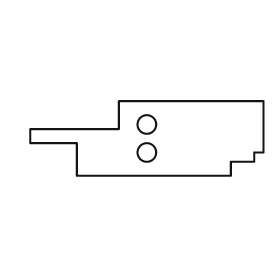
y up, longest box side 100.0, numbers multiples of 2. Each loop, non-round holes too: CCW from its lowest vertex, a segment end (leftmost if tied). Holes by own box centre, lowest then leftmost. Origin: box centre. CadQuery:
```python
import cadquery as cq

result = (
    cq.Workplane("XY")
    .moveTo(-30.0, -16.0)
    .lineTo(36.0, -16.0)
    .lineTo(36.0, -10.0)
    .lineTo(46.0, -10.0)
    .lineTo(46.0, -6.0)
    .lineTo(50.0, -6.0)
    .lineTo(50.0, 16.0)
    .lineTo(-12.0, 16.0)
    .lineTo(-12.0, 4.0)
    .lineTo(-50.0, 4.0)
    .lineTo(-50.0, -2.0)
    .lineTo(-30.0, -2.0)
    .close()
    .moveTo(0.0, -6.0)
    .circle(4.0)
    .moveTo(0.0, 6.0)
    .circle(4.0)
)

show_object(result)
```